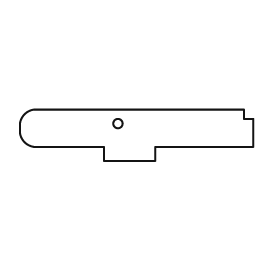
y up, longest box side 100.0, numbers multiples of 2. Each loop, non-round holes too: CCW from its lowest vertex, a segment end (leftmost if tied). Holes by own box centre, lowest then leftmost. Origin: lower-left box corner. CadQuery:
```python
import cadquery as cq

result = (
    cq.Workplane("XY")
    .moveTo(36.0, 0.0)
    .lineTo(58.0, 0.0)
    .lineTo(58.0, 6.0)
    .lineTo(100.0, 6.0)
    .lineTo(100.0, 18.0)
    .lineTo(96.0, 18.0)
    .lineTo(96.0, 22.0)
    .lineTo(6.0, 22.0)
    .threePointArc((2.0, 20.0), (0.0, 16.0))
    .lineTo(0.0, 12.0)
    .threePointArc((2.0, 8.0), (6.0, 6.0))
    .lineTo(36.0, 6.0)
    .close()
    .moveTo(42.0, 16.0)
    .circle(2.0)
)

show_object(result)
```